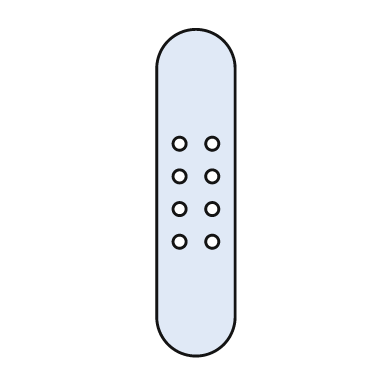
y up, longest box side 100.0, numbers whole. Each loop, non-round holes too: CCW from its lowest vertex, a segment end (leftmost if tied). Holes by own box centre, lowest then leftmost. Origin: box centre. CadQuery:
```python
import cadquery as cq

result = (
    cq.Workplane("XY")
    .moveTo(-12.0, -38.0)
    .threePointArc((0.0, -50.0), (12.0, -38.0))
    .lineTo(12.0, 38.0)
    .threePointArc((0.0, 50.0), (-12.0, 38.0))
    .close()
    .moveTo(-5.0, -15.0)
    .circle(2.0)
    .moveTo(5.0, -15.0)
    .circle(2.0)
    .moveTo(-5.0, -5.0)
    .circle(2.0)
    .moveTo(5.0, -5.0)
    .circle(2.0)
    .moveTo(-5.0, 5.0)
    .circle(2.0)
    .moveTo(5.0, 5.0)
    .circle(2.0)
    .moveTo(-5.0, 15.0)
    .circle(2.0)
    .moveTo(5.0, 15.0)
    .circle(2.0)
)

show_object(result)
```